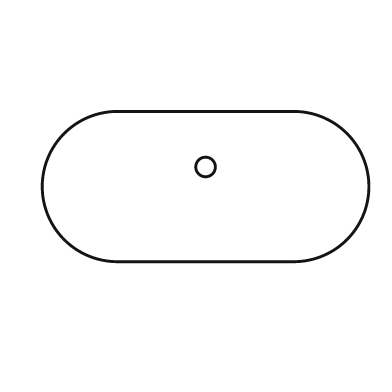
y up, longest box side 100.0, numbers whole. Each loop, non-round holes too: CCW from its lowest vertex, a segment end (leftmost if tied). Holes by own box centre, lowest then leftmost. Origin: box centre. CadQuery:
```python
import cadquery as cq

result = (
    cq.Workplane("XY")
    .moveTo(-27.0, -23.0)
    .lineTo(27.0, -23.0)
    .threePointArc((50.0, 0.0), (27.0, 23.0))
    .lineTo(-27.0, 23.0)
    .threePointArc((-50.0, 0.0), (-27.0, -23.0))
    .close()
    .moveTo(0.0, 6.0)
    .circle(3.0)
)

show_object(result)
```